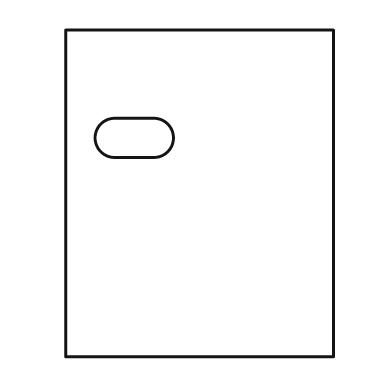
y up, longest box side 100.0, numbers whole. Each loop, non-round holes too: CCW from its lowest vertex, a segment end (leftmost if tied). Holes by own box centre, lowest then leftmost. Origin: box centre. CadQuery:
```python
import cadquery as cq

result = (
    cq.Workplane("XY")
    .moveTo(-41.0, -50.0)
    .lineTo(41.0, -50.0)
    .lineTo(41.0, 50.0)
    .lineTo(-41.0, 50.0)
    .close()
    .moveTo(-26.0, 11.0)
    .lineTo(-14.0, 11.0)
    .threePointArc((-8.0, 17.0), (-14.0, 23.0))
    .lineTo(-26.0, 23.0)
    .threePointArc((-32.0, 17.0), (-26.0, 11.0))
    .close()
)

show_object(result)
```